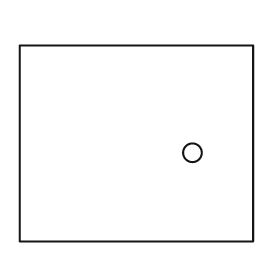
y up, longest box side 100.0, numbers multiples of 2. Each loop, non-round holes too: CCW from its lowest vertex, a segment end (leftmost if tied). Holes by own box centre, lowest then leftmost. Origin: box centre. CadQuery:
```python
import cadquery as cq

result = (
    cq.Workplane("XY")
    .moveTo(-50.0, -42.0)
    .lineTo(50.0, -42.0)
    .lineTo(50.0, 42.0)
    .lineTo(-50.0, 42.0)
    .close()
    .moveTo(24.0, -4.0)
    .circle(4.0)
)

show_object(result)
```